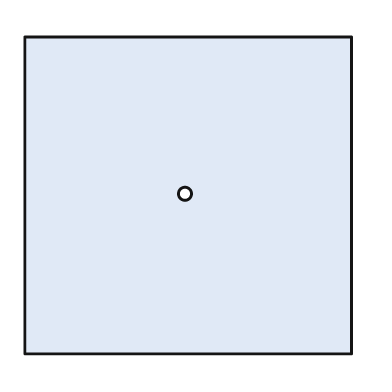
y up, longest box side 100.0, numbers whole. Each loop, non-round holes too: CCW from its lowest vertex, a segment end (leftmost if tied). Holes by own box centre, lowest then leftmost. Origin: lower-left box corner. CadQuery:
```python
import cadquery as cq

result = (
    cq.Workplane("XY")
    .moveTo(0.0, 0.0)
    .lineTo(100.0, 0.0)
    .lineTo(100.0, 97.0)
    .lineTo(0.0, 97.0)
    .close()
    .moveTo(49.0, 49.0)
    .circle(2.0)
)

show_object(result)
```